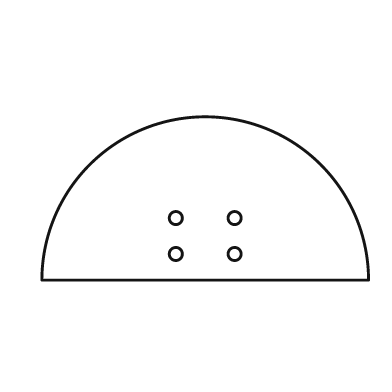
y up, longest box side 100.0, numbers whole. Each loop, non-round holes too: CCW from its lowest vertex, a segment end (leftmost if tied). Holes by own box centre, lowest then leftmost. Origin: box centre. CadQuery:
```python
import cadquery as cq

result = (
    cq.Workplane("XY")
    .moveTo(-50.0, -25.0)
    .lineTo(50.0, -25.0)
    .threePointArc((0.0, 25.0), (-50.0, -25.0))
    .close()
    .moveTo(-9.0, -17.0)
    .circle(2.0)
    .moveTo(9.0, -17.0)
    .circle(2.0)
    .moveTo(-9.0, -6.0)
    .circle(2.0)
    .moveTo(9.0, -6.0)
    .circle(2.0)
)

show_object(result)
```